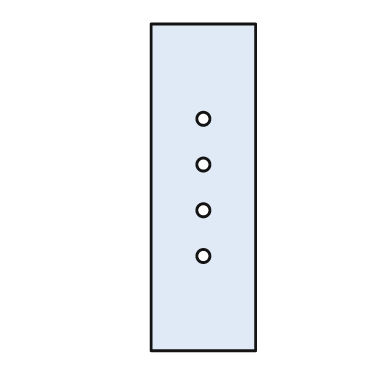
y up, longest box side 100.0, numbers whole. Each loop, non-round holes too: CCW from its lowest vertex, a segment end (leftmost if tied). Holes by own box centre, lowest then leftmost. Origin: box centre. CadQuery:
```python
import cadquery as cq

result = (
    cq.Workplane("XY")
    .moveTo(-16.0, -50.0)
    .lineTo(16.0, -50.0)
    .lineTo(16.0, 50.0)
    .lineTo(-16.0, 50.0)
    .close()
    .moveTo(0.0, -21.0)
    .circle(2.0)
    .moveTo(0.0, -7.0)
    .circle(2.0)
    .moveTo(0.0, 7.0)
    .circle(2.0)
    .moveTo(0.0, 21.0)
    .circle(2.0)
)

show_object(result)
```